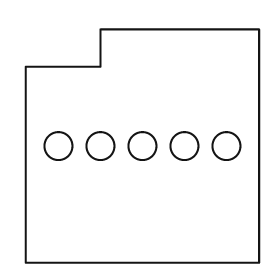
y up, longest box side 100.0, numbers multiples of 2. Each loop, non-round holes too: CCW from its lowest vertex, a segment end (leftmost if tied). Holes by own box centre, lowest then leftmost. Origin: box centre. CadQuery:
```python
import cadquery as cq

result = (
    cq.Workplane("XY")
    .moveTo(-50.0, -50.0)
    .lineTo(50.0, -50.0)
    .lineTo(50.0, 50.0)
    .lineTo(-18.0, 50.0)
    .lineTo(-18.0, 34.0)
    .lineTo(-50.0, 34.0)
    .close()
    .moveTo(-36.0, 0.0)
    .circle(6.0)
    .moveTo(-18.0, 0.0)
    .circle(6.0)
    .moveTo(0.0, 0.0)
    .circle(6.0)
    .moveTo(18.0, 0.0)
    .circle(6.0)
    .moveTo(36.0, 0.0)
    .circle(6.0)
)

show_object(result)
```